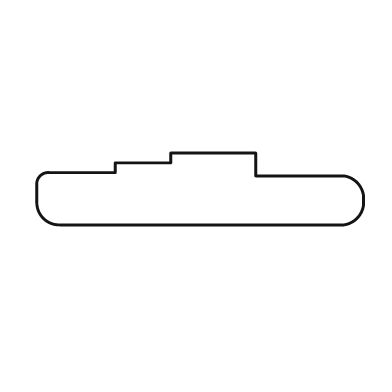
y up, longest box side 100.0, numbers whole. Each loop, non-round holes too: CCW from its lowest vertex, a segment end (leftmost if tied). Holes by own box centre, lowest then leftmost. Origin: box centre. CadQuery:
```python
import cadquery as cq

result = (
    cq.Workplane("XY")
    .moveTo(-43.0, -11.0)
    .lineTo(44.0, -11.0)
    .threePointArc((48.0, -9.0), (50.0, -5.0))
    .lineTo(50.0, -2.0)
    .threePointArc((48.0, 2.0), (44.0, 4.0))
    .lineTo(17.0, 4.0)
    .lineTo(17.0, 11.0)
    .lineTo(-9.0, 11.0)
    .lineTo(-9.0, 8.0)
    .lineTo(-26.0, 8.0)
    .lineTo(-26.0, 5.0)
    .lineTo(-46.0, 5.0)
    .threePointArc((-49.0, 4.0), (-50.0, 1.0))
    .lineTo(-50.0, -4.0)
    .threePointArc((-48.0, -9.0), (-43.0, -11.0))
    .close()
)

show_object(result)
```